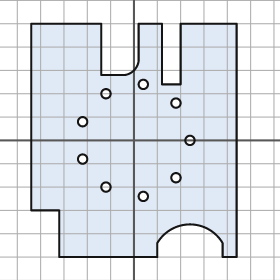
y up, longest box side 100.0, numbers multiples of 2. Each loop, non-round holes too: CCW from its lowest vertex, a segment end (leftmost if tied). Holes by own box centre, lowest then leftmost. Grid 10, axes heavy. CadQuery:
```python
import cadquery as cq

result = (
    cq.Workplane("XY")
    .moveTo(-32.0, -50.0)
    .lineTo(10.0, -50.0)
    .lineTo(10.0, -44.0)
    .threePointArc((24.0, -36.0), (38.0, -44.0))
    .lineTo(38.0, -50.0)
    .lineTo(44.0, -50.0)
    .lineTo(44.0, 50.0)
    .lineTo(20.0, 50.0)
    .lineTo(20.0, 24.0)
    .lineTo(12.0, 24.0)
    .lineTo(12.0, 50.0)
    .lineTo(2.0, 50.0)
    .lineTo(2.0, 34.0)
    .threePointArc((0.0, 30.0), (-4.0, 28.0))
    .lineTo(-14.0, 28.0)
    .lineTo(-14.0, 50.0)
    .lineTo(-44.0, 50.0)
    .lineTo(-44.0, -30.0)
    .lineTo(-32.0, -30.0)
    .close()
    .moveTo(4.0, -24.0)
    .circle(2.0)
    .moveTo(-12.0, -20.0)
    .circle(2.0)
    .moveTo(18.0, -16.0)
    .circle(2.0)
    .moveTo(-22.0, -8.0)
    .circle(2.0)
    .moveTo(24.0, 0.0)
    .circle(2.0)
    .moveTo(-22.0, 8.0)
    .circle(2.0)
    .moveTo(18.0, 16.0)
    .circle(2.0)
    .moveTo(-12.0, 20.0)
    .circle(2.0)
    .moveTo(4.0, 24.0)
    .circle(2.0)
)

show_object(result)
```